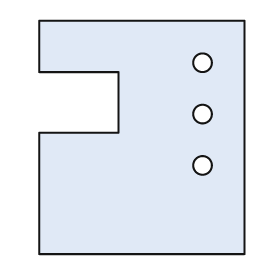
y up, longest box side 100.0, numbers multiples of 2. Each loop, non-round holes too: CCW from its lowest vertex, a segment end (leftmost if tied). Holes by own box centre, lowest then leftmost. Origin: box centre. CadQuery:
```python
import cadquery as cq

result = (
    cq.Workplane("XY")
    .moveTo(-44.0, -50.0)
    .lineTo(44.0, -50.0)
    .lineTo(44.0, 50.0)
    .lineTo(-44.0, 50.0)
    .lineTo(-44.0, 28.0)
    .lineTo(-10.0, 28.0)
    .lineTo(-10.0, 2.0)
    .lineTo(-44.0, 2.0)
    .close()
    .moveTo(26.0, -12.0)
    .circle(4.0)
    .moveTo(26.0, 10.0)
    .circle(4.0)
    .moveTo(26.0, 32.0)
    .circle(4.0)
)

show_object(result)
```